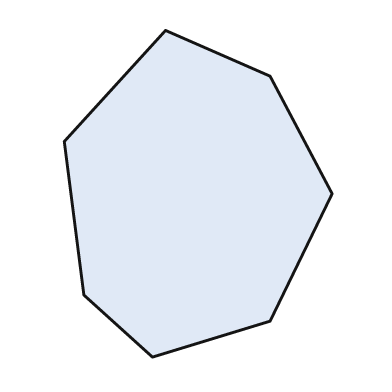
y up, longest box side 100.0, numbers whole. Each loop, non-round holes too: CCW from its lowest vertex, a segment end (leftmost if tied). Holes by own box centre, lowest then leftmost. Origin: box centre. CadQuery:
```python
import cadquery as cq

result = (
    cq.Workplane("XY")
    .moveTo(-14.0, -50.0)
    .lineTo(22.0, -39.0)
    .lineTo(41.0, 0.0)
    .lineTo(22.0, 36.0)
    .lineTo(-10.0, 50.0)
    .lineTo(-41.0, 16.0)
    .lineTo(-35.0, -31.0)
    .close()
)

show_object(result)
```